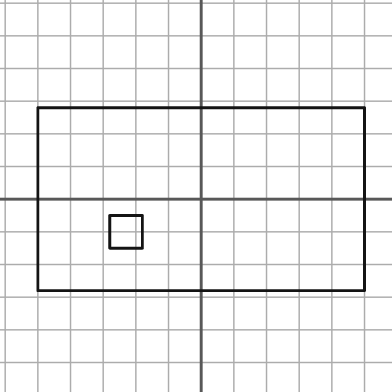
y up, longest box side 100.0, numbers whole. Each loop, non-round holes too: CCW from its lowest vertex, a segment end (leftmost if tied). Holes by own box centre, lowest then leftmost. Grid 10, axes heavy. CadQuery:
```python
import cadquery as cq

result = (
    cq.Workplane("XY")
    .moveTo(-50.0, -28.0)
    .lineTo(50.0, -28.0)
    .lineTo(50.0, 28.0)
    .lineTo(-50.0, 28.0)
    .close()
    .moveTo(-28.0, -15.0)
    .lineTo(-18.0, -15.0)
    .lineTo(-18.0, -5.0)
    .lineTo(-28.0, -5.0)
    .close()
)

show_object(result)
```